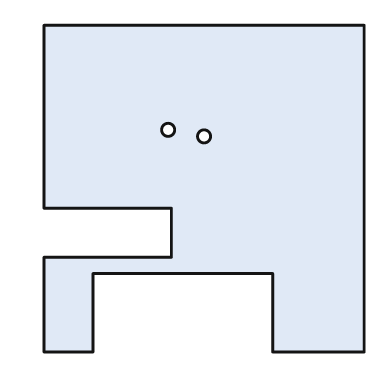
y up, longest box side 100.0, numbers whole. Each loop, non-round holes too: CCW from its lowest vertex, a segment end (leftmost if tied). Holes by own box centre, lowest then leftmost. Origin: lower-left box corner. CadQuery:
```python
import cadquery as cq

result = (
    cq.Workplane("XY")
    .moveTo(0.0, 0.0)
    .lineTo(15.0, 0.0)
    .lineTo(15.0, 24.0)
    .lineTo(70.0, 24.0)
    .lineTo(70.0, 0.0)
    .lineTo(98.0, 0.0)
    .lineTo(98.0, 100.0)
    .lineTo(0.0, 100.0)
    .lineTo(0.0, 44.0)
    .lineTo(39.0, 44.0)
    .lineTo(39.0, 29.0)
    .lineTo(0.0, 29.0)
    .close()
    .moveTo(49.0, 66.0)
    .circle(2.0)
    .moveTo(38.0, 68.0)
    .circle(2.0)
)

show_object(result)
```